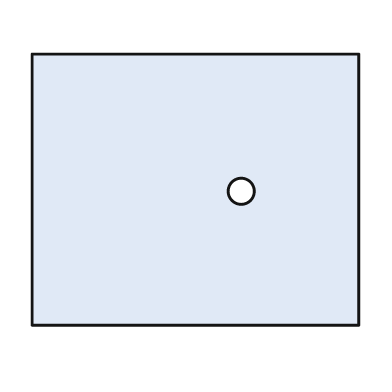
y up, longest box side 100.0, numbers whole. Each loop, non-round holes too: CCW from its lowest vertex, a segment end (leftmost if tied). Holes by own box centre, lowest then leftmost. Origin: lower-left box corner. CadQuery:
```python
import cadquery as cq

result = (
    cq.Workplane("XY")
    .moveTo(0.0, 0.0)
    .lineTo(100.0, 0.0)
    .lineTo(100.0, 83.0)
    .lineTo(0.0, 83.0)
    .close()
    .moveTo(64.0, 41.0)
    .circle(4.0)
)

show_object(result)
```